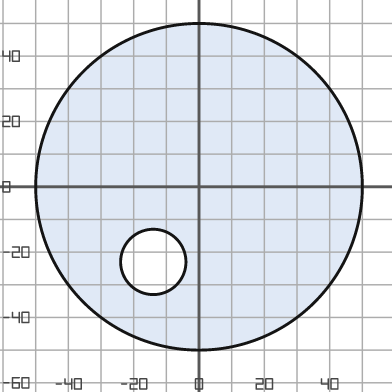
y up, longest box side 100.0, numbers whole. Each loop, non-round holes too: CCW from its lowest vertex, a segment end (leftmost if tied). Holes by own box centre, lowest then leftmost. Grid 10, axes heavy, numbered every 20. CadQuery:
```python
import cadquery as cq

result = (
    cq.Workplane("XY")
    .moveTo(0.0, 0.0)
    .circle(50.0)
    .moveTo(-14.0, -23.0)
    .circle(10.0)
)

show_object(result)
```